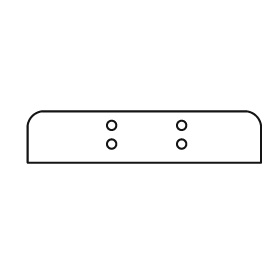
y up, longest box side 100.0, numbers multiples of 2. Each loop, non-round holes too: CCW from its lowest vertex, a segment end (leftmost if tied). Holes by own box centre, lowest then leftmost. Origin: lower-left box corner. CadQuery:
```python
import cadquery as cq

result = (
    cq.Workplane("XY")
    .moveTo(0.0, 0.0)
    .lineTo(100.0, 0.0)
    .lineTo(100.0, 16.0)
    .threePointArc((98.0, 20.0), (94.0, 22.0))
    .lineTo(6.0, 22.0)
    .threePointArc((2.0, 20.0), (0.0, 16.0))
    .close()
    .moveTo(36.0, 8.0)
    .circle(2.0)
    .moveTo(66.0, 8.0)
    .circle(2.0)
    .moveTo(36.0, 16.0)
    .circle(2.0)
    .moveTo(66.0, 16.0)
    .circle(2.0)
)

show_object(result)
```